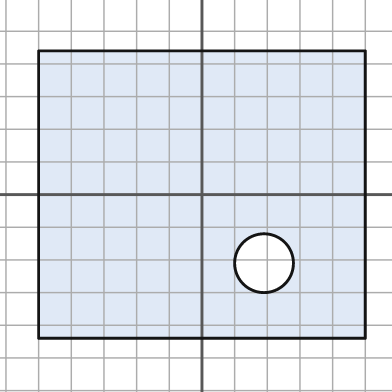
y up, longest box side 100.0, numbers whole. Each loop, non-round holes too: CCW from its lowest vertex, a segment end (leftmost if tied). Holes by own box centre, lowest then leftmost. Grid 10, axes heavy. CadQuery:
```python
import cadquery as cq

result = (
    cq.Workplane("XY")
    .moveTo(-50.0, -44.0)
    .lineTo(50.0, -44.0)
    .lineTo(50.0, 44.0)
    .lineTo(-50.0, 44.0)
    .close()
    .moveTo(19.0, -21.0)
    .circle(9.0)
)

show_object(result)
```